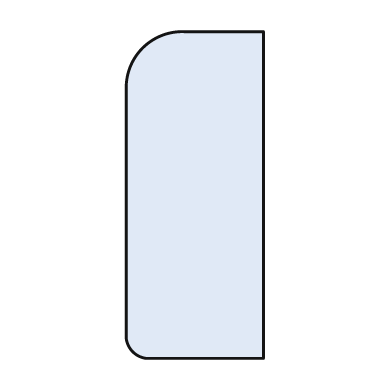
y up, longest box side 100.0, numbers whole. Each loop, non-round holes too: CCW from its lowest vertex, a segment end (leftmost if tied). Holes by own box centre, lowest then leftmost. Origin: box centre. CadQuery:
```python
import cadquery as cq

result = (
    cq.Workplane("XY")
    .moveTo(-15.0, -50.0)
    .lineTo(21.0, -50.0)
    .lineTo(21.0, 50.0)
    .lineTo(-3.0, 50.0)
    .threePointArc((-16.0, 45.0), (-21.0, 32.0))
    .lineTo(-21.0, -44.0)
    .threePointArc((-19.0, -48.0), (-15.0, -50.0))
    .close()
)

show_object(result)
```